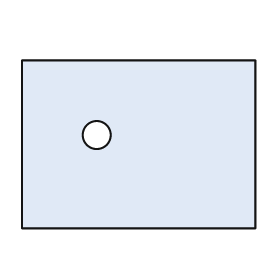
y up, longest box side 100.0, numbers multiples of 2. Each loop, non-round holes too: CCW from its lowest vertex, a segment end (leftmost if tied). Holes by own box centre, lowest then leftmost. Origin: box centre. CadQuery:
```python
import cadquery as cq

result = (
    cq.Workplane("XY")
    .moveTo(-50.0, -36.0)
    .lineTo(50.0, -36.0)
    .lineTo(50.0, 36.0)
    .lineTo(-50.0, 36.0)
    .close()
    .moveTo(-18.0, 4.0)
    .circle(6.0)
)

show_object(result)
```